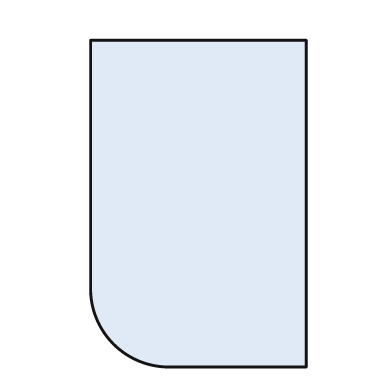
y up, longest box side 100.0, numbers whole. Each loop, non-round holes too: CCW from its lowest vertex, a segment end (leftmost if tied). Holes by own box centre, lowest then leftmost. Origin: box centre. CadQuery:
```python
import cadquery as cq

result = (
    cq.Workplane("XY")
    .moveTo(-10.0, -50.0)
    .lineTo(33.0, -50.0)
    .lineTo(33.0, 50.0)
    .lineTo(-33.0, 50.0)
    .lineTo(-33.0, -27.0)
    .threePointArc((-26.0, -43.0), (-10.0, -50.0))
    .close()
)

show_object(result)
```